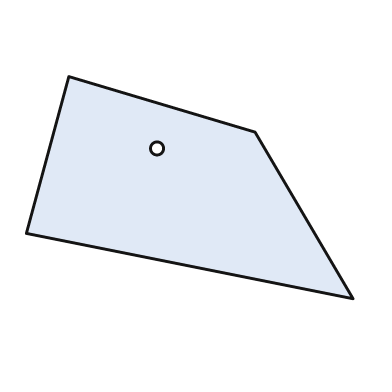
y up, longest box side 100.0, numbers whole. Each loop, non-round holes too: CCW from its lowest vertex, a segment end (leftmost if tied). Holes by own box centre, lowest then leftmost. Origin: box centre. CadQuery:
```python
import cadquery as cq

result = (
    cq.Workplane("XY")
    .moveTo(50.0, -34.0)
    .lineTo(20.0, 17.0)
    .lineTo(-37.0, 34.0)
    .lineTo(-50.0, -14.0)
    .close()
    .moveTo(-10.0, 12.0)
    .circle(2.0)
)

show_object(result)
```